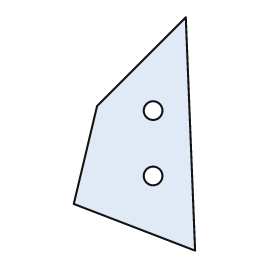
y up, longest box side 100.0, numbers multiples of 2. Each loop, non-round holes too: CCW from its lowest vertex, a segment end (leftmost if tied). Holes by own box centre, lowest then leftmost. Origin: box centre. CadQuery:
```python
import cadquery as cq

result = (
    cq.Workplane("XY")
    .moveTo(26.0, -50.0)
    .lineTo(22.0, 50.0)
    .lineTo(-16.0, 12.0)
    .lineTo(-26.0, -30.0)
    .close()
    .moveTo(8.0, -18.0)
    .circle(4.0)
    .moveTo(8.0, 10.0)
    .circle(4.0)
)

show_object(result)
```